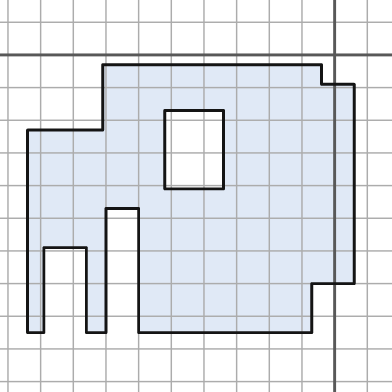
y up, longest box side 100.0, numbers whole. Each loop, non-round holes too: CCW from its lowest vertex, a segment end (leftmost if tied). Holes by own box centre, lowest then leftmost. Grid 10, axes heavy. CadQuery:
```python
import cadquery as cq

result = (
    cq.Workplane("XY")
    .moveTo(-94.0, -85.0)
    .lineTo(-89.0, -85.0)
    .lineTo(-89.0, -59.0)
    .lineTo(-76.0, -59.0)
    .lineTo(-76.0, -85.0)
    .lineTo(-70.0, -85.0)
    .lineTo(-70.0, -47.0)
    .lineTo(-60.0, -47.0)
    .lineTo(-60.0, -85.0)
    .lineTo(-7.0, -85.0)
    .lineTo(-7.0, -70.0)
    .lineTo(6.0, -70.0)
    .lineTo(6.0, -9.0)
    .lineTo(-4.0, -9.0)
    .lineTo(-4.0, -3.0)
    .lineTo(-71.0, -3.0)
    .lineTo(-71.0, -23.0)
    .lineTo(-94.0, -23.0)
    .close()
    .moveTo(-52.0, -41.0)
    .lineTo(-34.0, -41.0)
    .lineTo(-34.0, -17.0)
    .lineTo(-52.0, -17.0)
    .close()
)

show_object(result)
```